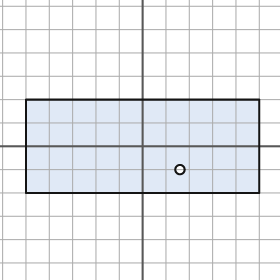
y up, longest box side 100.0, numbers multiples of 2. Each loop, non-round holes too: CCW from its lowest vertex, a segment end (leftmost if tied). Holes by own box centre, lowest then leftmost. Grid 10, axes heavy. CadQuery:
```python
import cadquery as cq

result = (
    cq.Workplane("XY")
    .moveTo(-50.0, -20.0)
    .lineTo(50.0, -20.0)
    .lineTo(50.0, 20.0)
    .lineTo(-50.0, 20.0)
    .close()
    .moveTo(16.0, -10.0)
    .circle(2.0)
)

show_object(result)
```